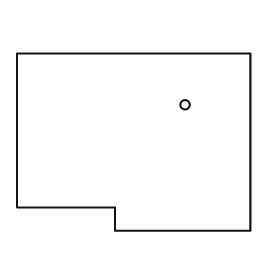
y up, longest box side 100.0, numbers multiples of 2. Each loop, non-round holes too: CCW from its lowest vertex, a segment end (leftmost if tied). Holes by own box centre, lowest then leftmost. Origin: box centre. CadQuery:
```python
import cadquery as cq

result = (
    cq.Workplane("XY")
    .moveTo(-8.0, -38.0)
    .lineTo(50.0, -38.0)
    .lineTo(50.0, 38.0)
    .lineTo(-50.0, 38.0)
    .lineTo(-50.0, -28.0)
    .lineTo(-8.0, -28.0)
    .close()
    .moveTo(22.0, 16.0)
    .circle(2.0)
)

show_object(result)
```